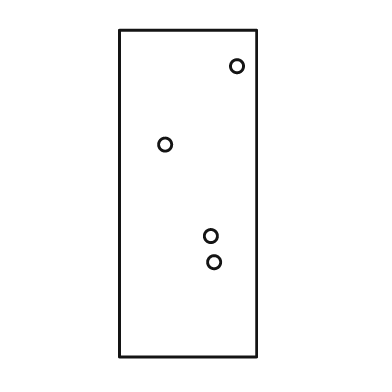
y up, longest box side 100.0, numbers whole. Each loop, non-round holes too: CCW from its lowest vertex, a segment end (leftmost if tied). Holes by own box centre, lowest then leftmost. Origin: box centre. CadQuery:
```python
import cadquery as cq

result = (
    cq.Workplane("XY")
    .moveTo(-21.0, -50.0)
    .lineTo(21.0, -50.0)
    .lineTo(21.0, 50.0)
    .lineTo(-21.0, 50.0)
    .close()
    .moveTo(8.0, -21.0)
    .circle(2.0)
    .moveTo(7.0, -13.0)
    .circle(2.0)
    .moveTo(-7.0, 15.0)
    .circle(2.0)
    .moveTo(15.0, 39.0)
    .circle(2.0)
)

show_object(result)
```